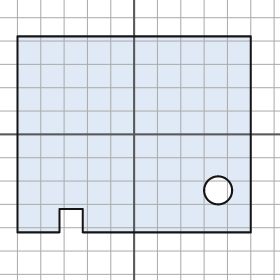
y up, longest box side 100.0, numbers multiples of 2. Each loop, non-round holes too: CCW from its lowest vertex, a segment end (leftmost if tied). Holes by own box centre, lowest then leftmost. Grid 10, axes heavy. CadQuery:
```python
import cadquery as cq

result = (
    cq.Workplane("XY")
    .moveTo(-50.0, -42.0)
    .lineTo(-32.0, -42.0)
    .lineTo(-32.0, -32.0)
    .lineTo(-22.0, -32.0)
    .lineTo(-22.0, -42.0)
    .lineTo(50.0, -42.0)
    .lineTo(50.0, 42.0)
    .lineTo(-50.0, 42.0)
    .close()
    .moveTo(36.0, -24.0)
    .circle(6.0)
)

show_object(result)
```